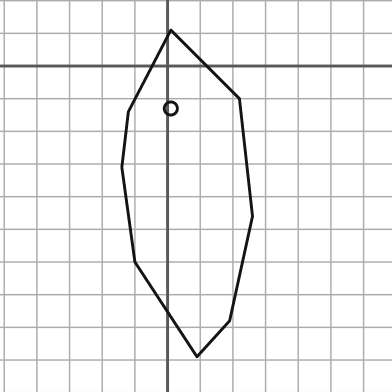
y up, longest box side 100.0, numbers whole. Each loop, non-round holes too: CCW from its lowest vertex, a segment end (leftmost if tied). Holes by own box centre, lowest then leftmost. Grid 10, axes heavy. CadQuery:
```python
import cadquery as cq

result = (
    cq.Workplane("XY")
    .moveTo(9.0, -89.0)
    .lineTo(19.0, -78.0)
    .lineTo(26.0, -46.0)
    .lineTo(22.0, -10.0)
    .lineTo(1.0, 11.0)
    .lineTo(-12.0, -14.0)
    .lineTo(-14.0, -31.0)
    .lineTo(-10.0, -60.0)
    .close()
    .moveTo(1.0, -13.0)
    .circle(2.0)
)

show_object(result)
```